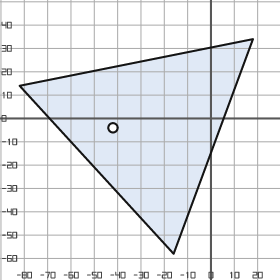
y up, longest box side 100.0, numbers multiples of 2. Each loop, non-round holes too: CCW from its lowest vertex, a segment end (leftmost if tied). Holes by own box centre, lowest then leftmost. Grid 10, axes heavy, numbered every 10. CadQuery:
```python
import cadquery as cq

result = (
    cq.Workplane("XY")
    .moveTo(-16.0, -58.0)
    .lineTo(18.0, 34.0)
    .lineTo(-82.0, 14.0)
    .close()
    .moveTo(-42.0, -4.0)
    .circle(2.0)
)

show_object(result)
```